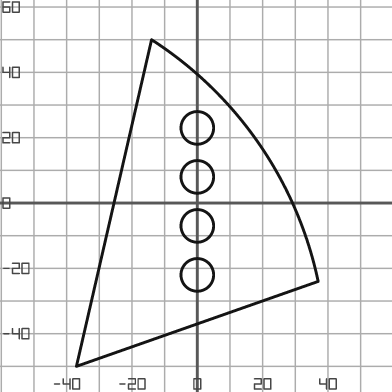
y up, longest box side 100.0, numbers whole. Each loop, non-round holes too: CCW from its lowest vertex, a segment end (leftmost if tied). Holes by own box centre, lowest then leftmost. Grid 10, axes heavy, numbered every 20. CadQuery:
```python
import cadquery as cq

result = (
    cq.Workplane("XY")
    .moveTo(-37.0, -50.0)
    .lineTo(37.0, -24.0)
    .threePointArc((19.0, 18.0), (-14.0, 50.0))
    .close()
    .moveTo(0.0, -22.0)
    .circle(5.0)
    .moveTo(0.0, -7.0)
    .circle(5.0)
    .moveTo(0.0, 8.0)
    .circle(5.0)
    .moveTo(0.0, 23.0)
    .circle(5.0)
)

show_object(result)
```